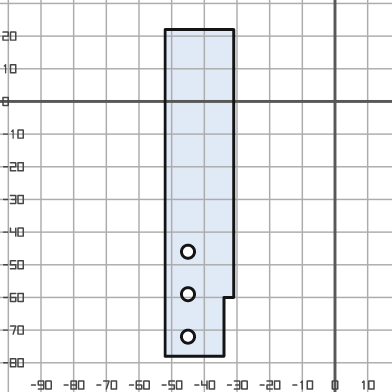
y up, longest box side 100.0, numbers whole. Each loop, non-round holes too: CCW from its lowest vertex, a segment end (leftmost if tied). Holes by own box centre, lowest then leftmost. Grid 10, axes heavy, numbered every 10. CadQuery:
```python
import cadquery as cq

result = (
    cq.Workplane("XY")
    .moveTo(-52.0, -78.0)
    .lineTo(-34.0, -78.0)
    .lineTo(-34.0, -60.0)
    .lineTo(-31.0, -60.0)
    .lineTo(-31.0, 22.0)
    .lineTo(-52.0, 22.0)
    .close()
    .moveTo(-45.0, -72.0)
    .circle(2.0)
    .moveTo(-45.0, -59.0)
    .circle(2.0)
    .moveTo(-45.0, -46.0)
    .circle(2.0)
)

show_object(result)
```